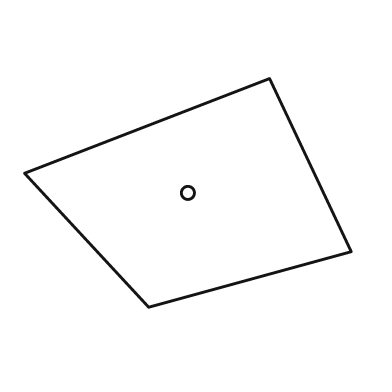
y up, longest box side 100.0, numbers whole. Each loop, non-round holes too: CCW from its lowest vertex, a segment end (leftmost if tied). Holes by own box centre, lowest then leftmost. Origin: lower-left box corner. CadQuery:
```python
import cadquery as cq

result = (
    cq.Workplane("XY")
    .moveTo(38.0, 0.0)
    .lineTo(100.0, 17.0)
    .lineTo(75.0, 70.0)
    .lineTo(0.0, 41.0)
    .close()
    .moveTo(50.0, 35.0)
    .circle(2.0)
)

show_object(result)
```